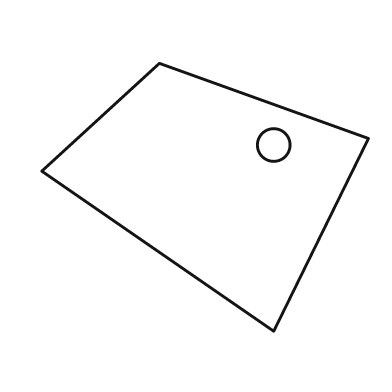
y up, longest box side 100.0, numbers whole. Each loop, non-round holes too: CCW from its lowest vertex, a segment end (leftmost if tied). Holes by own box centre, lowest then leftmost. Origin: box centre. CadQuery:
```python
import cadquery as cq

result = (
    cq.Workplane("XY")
    .moveTo(21.0, -41.0)
    .lineTo(50.0, 18.0)
    .lineTo(-14.0, 41.0)
    .lineTo(-50.0, 8.0)
    .close()
    .moveTo(21.0, 16.0)
    .circle(5.0)
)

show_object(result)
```